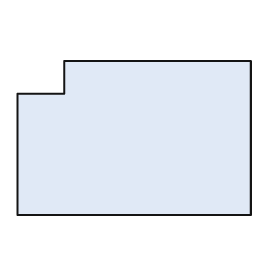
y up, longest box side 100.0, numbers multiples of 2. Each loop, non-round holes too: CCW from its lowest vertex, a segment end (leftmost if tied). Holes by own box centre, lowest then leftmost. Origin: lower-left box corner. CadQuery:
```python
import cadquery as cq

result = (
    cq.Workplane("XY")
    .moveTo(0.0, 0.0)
    .lineTo(100.0, 0.0)
    .lineTo(100.0, 66.0)
    .lineTo(20.0, 66.0)
    .lineTo(20.0, 52.0)
    .lineTo(0.0, 52.0)
    .close()
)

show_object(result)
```